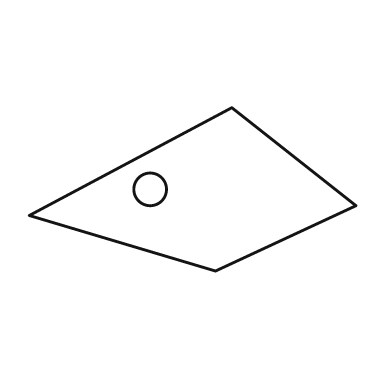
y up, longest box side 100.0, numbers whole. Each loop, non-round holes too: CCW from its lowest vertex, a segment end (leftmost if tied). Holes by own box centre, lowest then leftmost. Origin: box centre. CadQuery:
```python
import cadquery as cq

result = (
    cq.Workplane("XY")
    .moveTo(7.0, -25.0)
    .lineTo(50.0, -5.0)
    .lineTo(12.0, 25.0)
    .lineTo(-50.0, -8.0)
    .close()
    .moveTo(-13.0, 0.0)
    .circle(5.0)
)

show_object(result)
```